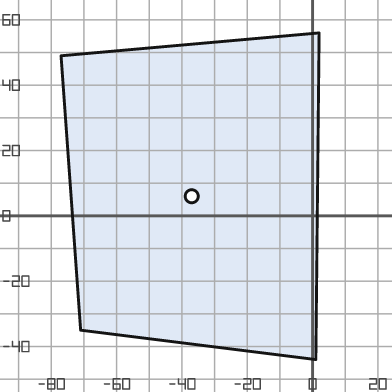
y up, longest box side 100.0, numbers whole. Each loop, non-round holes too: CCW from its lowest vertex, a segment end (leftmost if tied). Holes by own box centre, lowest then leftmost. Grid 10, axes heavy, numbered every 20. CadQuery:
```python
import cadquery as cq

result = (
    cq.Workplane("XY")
    .moveTo(1.0, -44.0)
    .lineTo(2.0, 56.0)
    .lineTo(-77.0, 49.0)
    .lineTo(-71.0, -35.0)
    .close()
    .moveTo(-37.0, 6.0)
    .circle(2.0)
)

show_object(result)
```